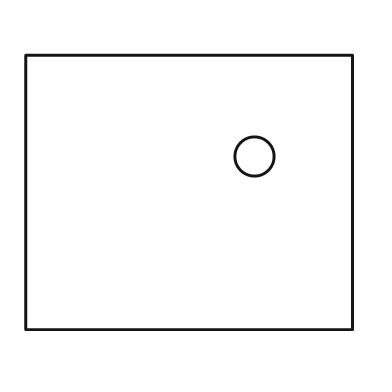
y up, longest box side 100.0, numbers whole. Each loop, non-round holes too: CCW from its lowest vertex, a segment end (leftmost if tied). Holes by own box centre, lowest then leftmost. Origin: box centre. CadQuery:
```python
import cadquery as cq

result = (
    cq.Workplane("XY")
    .moveTo(-50.0, -42.0)
    .lineTo(50.0, -42.0)
    .lineTo(50.0, 42.0)
    .lineTo(-50.0, 42.0)
    .close()
    .moveTo(20.0, 11.0)
    .circle(6.0)
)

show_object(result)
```